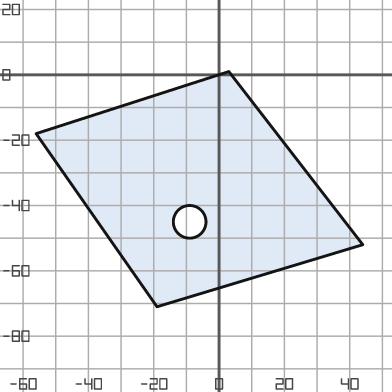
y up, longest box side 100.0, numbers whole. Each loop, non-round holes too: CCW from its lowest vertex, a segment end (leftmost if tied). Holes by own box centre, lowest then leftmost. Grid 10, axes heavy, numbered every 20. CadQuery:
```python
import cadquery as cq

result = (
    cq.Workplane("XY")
    .moveTo(-19.0, -71.0)
    .lineTo(44.0, -52.0)
    .lineTo(3.0, 1.0)
    .lineTo(-56.0, -18.0)
    .close()
    .moveTo(-9.0, -45.0)
    .circle(5.0)
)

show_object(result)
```